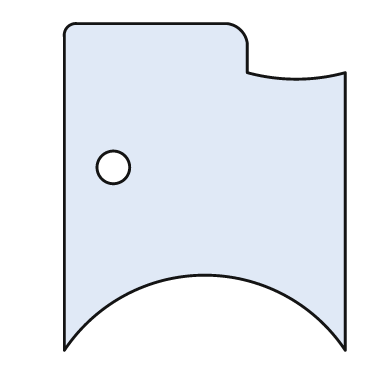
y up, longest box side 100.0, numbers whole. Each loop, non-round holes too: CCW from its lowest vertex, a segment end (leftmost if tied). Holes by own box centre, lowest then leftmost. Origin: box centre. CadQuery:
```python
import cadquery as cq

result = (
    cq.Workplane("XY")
    .moveTo(-43.0, -50.0)
    .threePointArc((0.0, -27.0), (43.0, -50.0))
    .lineTo(43.0, 35.0)
    .threePointArc((28.0, 33.0), (13.0, 35.0))
    .lineTo(13.0, 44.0)
    .threePointArc((11.0, 48.0), (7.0, 50.0))
    .lineTo(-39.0, 50.0)
    .threePointArc((-42.0, 49.0), (-43.0, 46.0))
    .close()
    .moveTo(-28.0, 6.0)
    .circle(5.0)
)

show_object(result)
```